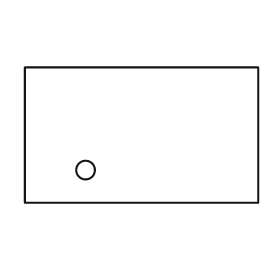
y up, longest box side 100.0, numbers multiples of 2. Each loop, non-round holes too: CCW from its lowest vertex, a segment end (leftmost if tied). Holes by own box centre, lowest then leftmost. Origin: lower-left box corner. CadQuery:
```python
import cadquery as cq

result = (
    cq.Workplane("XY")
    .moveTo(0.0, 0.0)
    .lineTo(100.0, 0.0)
    .lineTo(100.0, 58.0)
    .lineTo(0.0, 58.0)
    .close()
    .moveTo(26.0, 14.0)
    .circle(4.0)
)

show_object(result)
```